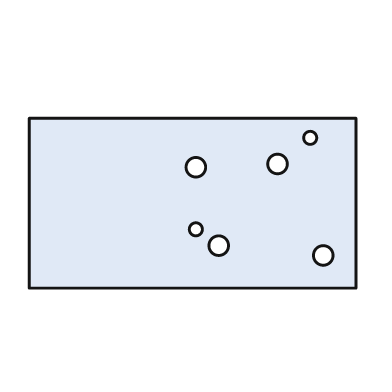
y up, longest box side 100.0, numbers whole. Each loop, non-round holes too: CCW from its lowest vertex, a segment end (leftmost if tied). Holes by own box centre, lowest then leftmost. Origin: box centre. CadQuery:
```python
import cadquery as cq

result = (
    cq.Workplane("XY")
    .moveTo(-50.0, -26.0)
    .lineTo(50.0, -26.0)
    .lineTo(50.0, 26.0)
    .lineTo(-50.0, 26.0)
    .close()
    .moveTo(40.0, -16.0)
    .circle(3.0)
    .moveTo(8.0, -13.0)
    .circle(3.0)
    .moveTo(1.0, -8.0)
    .circle(2.0)
    .moveTo(1.0, 11.0)
    .circle(3.0)
    .moveTo(26.0, 12.0)
    .circle(3.0)
    .moveTo(36.0, 20.0)
    .circle(2.0)
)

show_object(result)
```